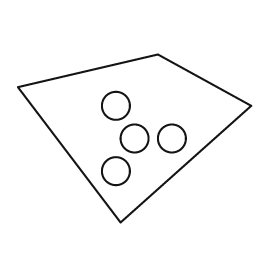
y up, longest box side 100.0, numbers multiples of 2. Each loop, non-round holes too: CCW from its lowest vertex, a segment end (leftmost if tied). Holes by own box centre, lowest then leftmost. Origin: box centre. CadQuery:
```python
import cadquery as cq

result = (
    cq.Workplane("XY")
    .moveTo(-6.0, -36.0)
    .lineTo(50.0, 14.0)
    .lineTo(10.0, 36.0)
    .lineTo(-50.0, 22.0)
    .close()
    .moveTo(-8.0, -14.0)
    .circle(6.0)
    .moveTo(0.0, 0.0)
    .circle(6.0)
    .moveTo(16.0, 0.0)
    .circle(6.0)
    .moveTo(-8.0, 14.0)
    .circle(6.0)
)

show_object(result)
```